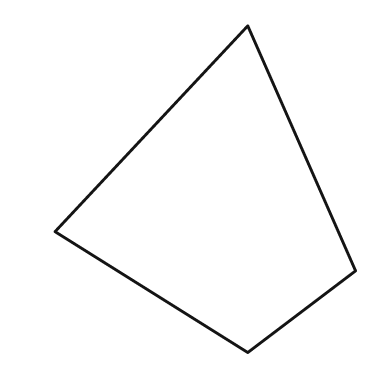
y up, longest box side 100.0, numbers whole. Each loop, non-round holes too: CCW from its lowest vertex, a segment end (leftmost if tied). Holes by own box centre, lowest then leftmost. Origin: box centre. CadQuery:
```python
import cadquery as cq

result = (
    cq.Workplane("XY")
    .moveTo(13.0, -50.0)
    .lineTo(46.0, -25.0)
    .lineTo(13.0, 50.0)
    .lineTo(-46.0, -13.0)
    .close()
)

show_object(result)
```